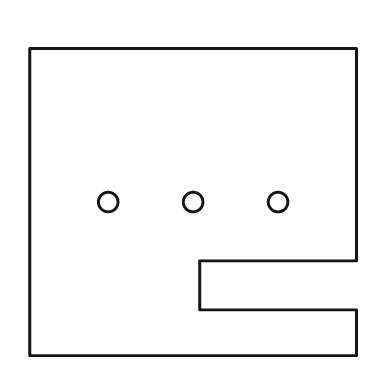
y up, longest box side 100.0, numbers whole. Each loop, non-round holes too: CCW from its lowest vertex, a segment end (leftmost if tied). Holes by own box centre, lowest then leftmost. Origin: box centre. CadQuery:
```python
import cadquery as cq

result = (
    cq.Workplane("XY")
    .moveTo(-50.0, -47.0)
    .lineTo(50.0, -47.0)
    .lineTo(50.0, -33.0)
    .lineTo(2.0, -33.0)
    .lineTo(2.0, -18.0)
    .lineTo(50.0, -18.0)
    .lineTo(50.0, 47.0)
    .lineTo(-50.0, 47.0)
    .close()
    .moveTo(-26.0, 0.0)
    .circle(3.0)
    .moveTo(0.0, 0.0)
    .circle(3.0)
    .moveTo(26.0, 0.0)
    .circle(3.0)
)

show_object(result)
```